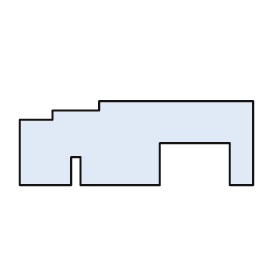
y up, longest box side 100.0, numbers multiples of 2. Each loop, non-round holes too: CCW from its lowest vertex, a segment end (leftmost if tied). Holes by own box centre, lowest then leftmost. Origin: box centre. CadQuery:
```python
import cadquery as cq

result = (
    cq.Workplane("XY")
    .moveTo(-50.0, -18.0)
    .lineTo(-28.0, -18.0)
    .lineTo(-28.0, -6.0)
    .lineTo(-24.0, -6.0)
    .lineTo(-24.0, -18.0)
    .lineTo(10.0, -18.0)
    .lineTo(10.0, 0.0)
    .lineTo(40.0, 0.0)
    .lineTo(40.0, -18.0)
    .lineTo(50.0, -18.0)
    .lineTo(50.0, 18.0)
    .lineTo(-16.0, 18.0)
    .lineTo(-16.0, 14.0)
    .lineTo(-36.0, 14.0)
    .lineTo(-36.0, 10.0)
    .lineTo(-50.0, 10.0)
    .close()
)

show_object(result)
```